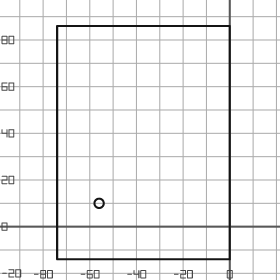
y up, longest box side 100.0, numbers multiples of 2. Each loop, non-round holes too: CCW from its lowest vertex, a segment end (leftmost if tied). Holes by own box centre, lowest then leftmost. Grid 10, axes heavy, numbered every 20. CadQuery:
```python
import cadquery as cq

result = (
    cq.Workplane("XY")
    .moveTo(-74.0, -14.0)
    .lineTo(0.0, -14.0)
    .lineTo(0.0, 86.0)
    .lineTo(-74.0, 86.0)
    .close()
    .moveTo(-56.0, 10.0)
    .circle(2.0)
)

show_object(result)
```